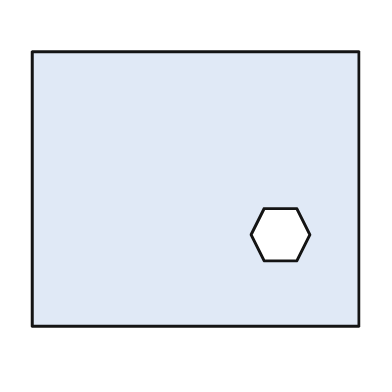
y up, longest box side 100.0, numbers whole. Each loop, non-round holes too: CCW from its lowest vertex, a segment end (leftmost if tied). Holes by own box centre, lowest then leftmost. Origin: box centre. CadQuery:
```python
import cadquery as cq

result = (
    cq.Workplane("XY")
    .moveTo(-50.0, -42.0)
    .lineTo(50.0, -42.0)
    .lineTo(50.0, 42.0)
    .lineTo(-50.0, 42.0)
    .close()
    .moveTo(21.0, -22.0)
    .lineTo(31.0, -22.0)
    .lineTo(35.0, -14.0)
    .lineTo(31.0, -6.0)
    .lineTo(21.0, -6.0)
    .lineTo(17.0, -14.0)
    .close()
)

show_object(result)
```